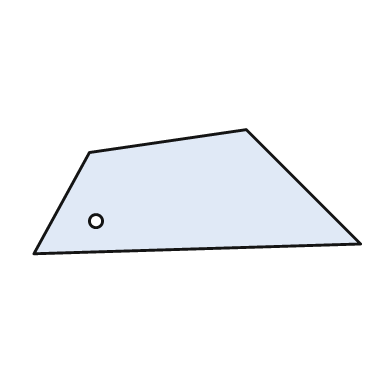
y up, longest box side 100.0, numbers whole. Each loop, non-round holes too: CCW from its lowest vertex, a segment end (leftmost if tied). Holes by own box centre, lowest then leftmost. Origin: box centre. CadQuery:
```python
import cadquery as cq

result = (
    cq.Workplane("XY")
    .moveTo(-50.0, -19.0)
    .lineTo(50.0, -16.0)
    .lineTo(15.0, 19.0)
    .lineTo(-33.0, 12.0)
    .close()
    .moveTo(-31.0, -9.0)
    .circle(2.0)
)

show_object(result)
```